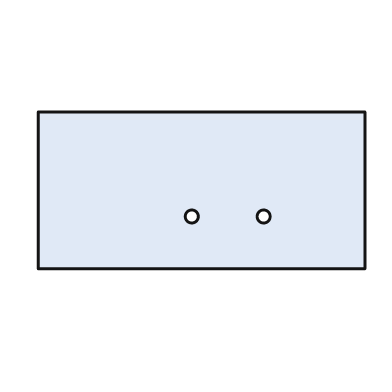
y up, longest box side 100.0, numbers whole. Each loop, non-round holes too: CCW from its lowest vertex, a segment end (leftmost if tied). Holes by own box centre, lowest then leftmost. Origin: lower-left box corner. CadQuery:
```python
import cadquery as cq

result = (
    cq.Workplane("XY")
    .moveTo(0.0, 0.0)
    .lineTo(100.0, 0.0)
    .lineTo(100.0, 48.0)
    .lineTo(0.0, 48.0)
    .close()
    .moveTo(47.0, 16.0)
    .circle(2.0)
    .moveTo(69.0, 16.0)
    .circle(2.0)
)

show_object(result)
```